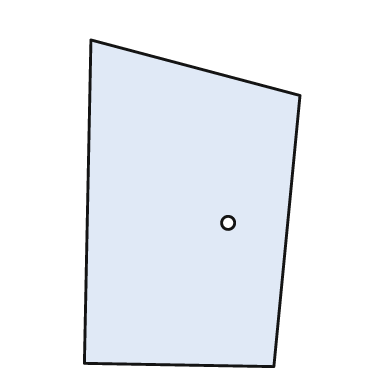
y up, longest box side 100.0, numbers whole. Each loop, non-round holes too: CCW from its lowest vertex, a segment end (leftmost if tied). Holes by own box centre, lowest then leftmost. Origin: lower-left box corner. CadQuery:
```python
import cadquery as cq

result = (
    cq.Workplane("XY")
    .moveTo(58.0, 0.0)
    .lineTo(66.0, 83.0)
    .lineTo(2.0, 100.0)
    .lineTo(0.0, 1.0)
    .close()
    .moveTo(44.0, 44.0)
    .circle(2.0)
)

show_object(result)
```